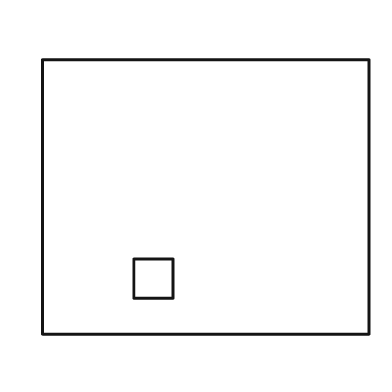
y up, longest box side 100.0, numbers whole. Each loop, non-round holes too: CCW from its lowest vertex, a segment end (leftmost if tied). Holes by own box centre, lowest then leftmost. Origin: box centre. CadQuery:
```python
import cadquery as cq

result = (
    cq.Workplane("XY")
    .moveTo(-50.0, -42.0)
    .lineTo(50.0, -42.0)
    .lineTo(50.0, 42.0)
    .lineTo(-50.0, 42.0)
    .close()
    .moveTo(-22.0, -31.0)
    .lineTo(-10.0, -31.0)
    .lineTo(-10.0, -19.0)
    .lineTo(-22.0, -19.0)
    .close()
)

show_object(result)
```